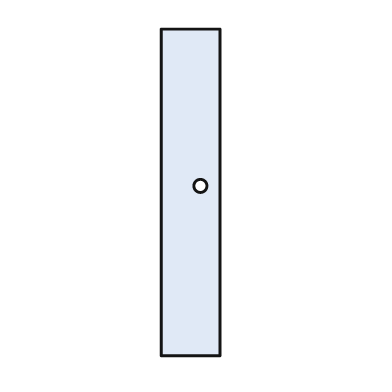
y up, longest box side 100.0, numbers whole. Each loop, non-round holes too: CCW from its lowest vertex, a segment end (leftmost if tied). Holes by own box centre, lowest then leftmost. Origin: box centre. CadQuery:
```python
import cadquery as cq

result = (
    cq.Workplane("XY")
    .moveTo(-9.0, -50.0)
    .lineTo(9.0, -50.0)
    .lineTo(9.0, 50.0)
    .lineTo(-9.0, 50.0)
    .close()
    .moveTo(3.0, 2.0)
    .circle(2.0)
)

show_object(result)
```